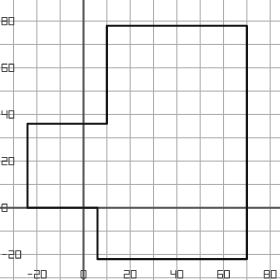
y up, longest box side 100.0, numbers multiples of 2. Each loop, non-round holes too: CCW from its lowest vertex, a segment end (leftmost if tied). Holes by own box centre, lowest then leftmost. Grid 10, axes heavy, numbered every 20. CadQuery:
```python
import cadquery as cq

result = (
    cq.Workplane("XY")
    .moveTo(6.0, -22.0)
    .lineTo(70.0, -22.0)
    .lineTo(70.0, 78.0)
    .lineTo(10.0, 78.0)
    .lineTo(10.0, 36.0)
    .lineTo(-24.0, 36.0)
    .lineTo(-24.0, 0.0)
    .lineTo(6.0, 0.0)
    .close()
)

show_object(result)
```